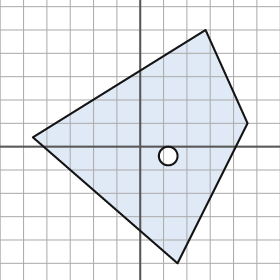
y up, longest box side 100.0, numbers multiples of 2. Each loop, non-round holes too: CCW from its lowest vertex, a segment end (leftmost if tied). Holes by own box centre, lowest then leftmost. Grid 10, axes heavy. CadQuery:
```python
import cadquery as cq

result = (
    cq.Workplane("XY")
    .moveTo(16.0, -50.0)
    .lineTo(46.0, 10.0)
    .lineTo(28.0, 50.0)
    .lineTo(-46.0, 4.0)
    .close()
    .moveTo(12.0, -4.0)
    .circle(4.0)
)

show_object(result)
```